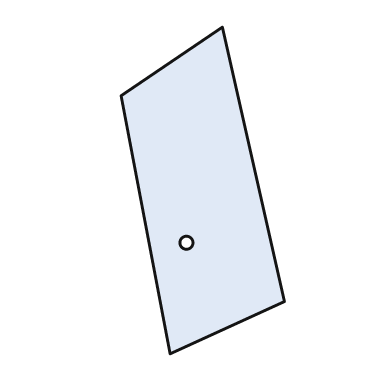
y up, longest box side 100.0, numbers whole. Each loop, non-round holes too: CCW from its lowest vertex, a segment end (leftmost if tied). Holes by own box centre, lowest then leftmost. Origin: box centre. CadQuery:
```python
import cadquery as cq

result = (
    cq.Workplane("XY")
    .moveTo(-10.0, -50.0)
    .lineTo(25.0, -34.0)
    .lineTo(6.0, 50.0)
    .lineTo(-25.0, 29.0)
    .close()
    .moveTo(-5.0, -16.0)
    .circle(2.0)
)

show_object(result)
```